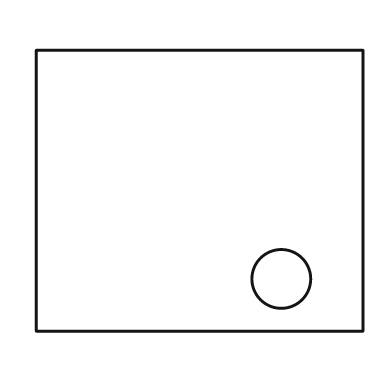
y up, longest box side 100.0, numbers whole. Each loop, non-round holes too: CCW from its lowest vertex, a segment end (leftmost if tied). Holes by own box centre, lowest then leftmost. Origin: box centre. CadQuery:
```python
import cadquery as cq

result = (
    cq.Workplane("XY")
    .moveTo(-50.0, -43.0)
    .lineTo(50.0, -43.0)
    .lineTo(50.0, 43.0)
    .lineTo(-50.0, 43.0)
    .close()
    .moveTo(25.0, -27.0)
    .circle(9.0)
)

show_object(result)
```